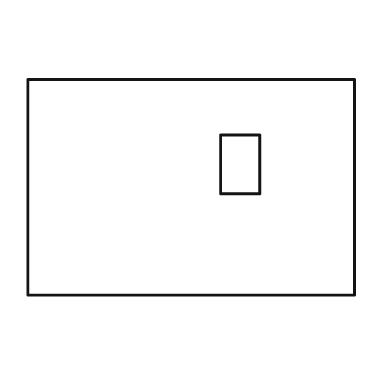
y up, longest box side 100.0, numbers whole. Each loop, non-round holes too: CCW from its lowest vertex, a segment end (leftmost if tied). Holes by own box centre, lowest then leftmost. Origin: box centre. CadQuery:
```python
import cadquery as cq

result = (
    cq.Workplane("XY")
    .moveTo(-50.0, -33.0)
    .lineTo(50.0, -33.0)
    .lineTo(50.0, 33.0)
    .lineTo(-50.0, 33.0)
    .close()
    .moveTo(9.0, -2.0)
    .lineTo(21.0, -2.0)
    .lineTo(21.0, 16.0)
    .lineTo(9.0, 16.0)
    .close()
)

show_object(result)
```